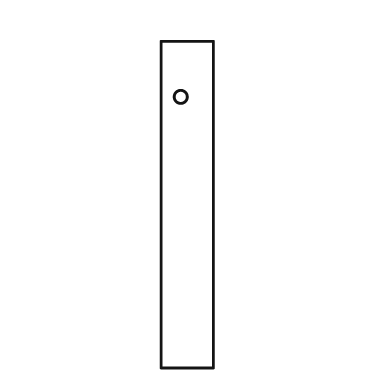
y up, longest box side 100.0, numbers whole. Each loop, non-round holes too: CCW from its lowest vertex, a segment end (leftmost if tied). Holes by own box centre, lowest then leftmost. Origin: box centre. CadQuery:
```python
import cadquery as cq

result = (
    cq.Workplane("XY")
    .moveTo(-8.0, -50.0)
    .lineTo(8.0, -50.0)
    .lineTo(8.0, 50.0)
    .lineTo(-8.0, 50.0)
    .close()
    .moveTo(-2.0, 33.0)
    .circle(2.0)
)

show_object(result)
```